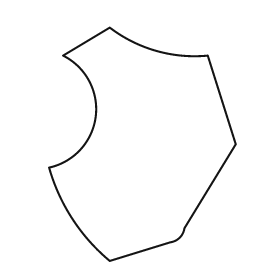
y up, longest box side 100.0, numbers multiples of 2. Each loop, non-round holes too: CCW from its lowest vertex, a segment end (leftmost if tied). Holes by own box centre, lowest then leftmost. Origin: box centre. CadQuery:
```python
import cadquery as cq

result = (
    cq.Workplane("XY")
    .moveTo(-14.0, -50.0)
    .lineTo(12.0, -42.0)
    .threePointArc((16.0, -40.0), (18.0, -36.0))
    .lineTo(40.0, 0.0)
    .lineTo(28.0, 38.0)
    .threePointArc((6.0, 40.0), (-14.0, 50.0))
    .lineTo(-34.0, 38.0)
    .threePointArc((-20.0, 12.0), (-40.0, -10.0))
    .threePointArc((-30.0, -32.0), (-14.0, -50.0))
    .close()
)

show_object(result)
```